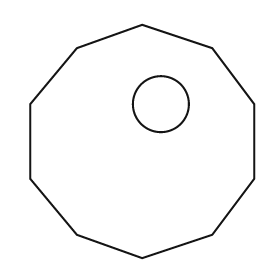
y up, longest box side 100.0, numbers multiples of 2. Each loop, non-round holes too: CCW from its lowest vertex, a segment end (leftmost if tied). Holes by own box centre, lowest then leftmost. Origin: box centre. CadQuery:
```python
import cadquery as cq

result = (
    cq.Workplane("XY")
    .moveTo(0.0, -50.0)
    .lineTo(30.0, -40.0)
    .lineTo(48.0, -16.0)
    .lineTo(48.0, 16.0)
    .lineTo(30.0, 40.0)
    .lineTo(0.0, 50.0)
    .lineTo(-28.0, 40.0)
    .lineTo(-48.0, 16.0)
    .lineTo(-48.0, -16.0)
    .lineTo(-28.0, -40.0)
    .close()
    .moveTo(8.0, 16.0)
    .circle(12.0)
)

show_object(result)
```